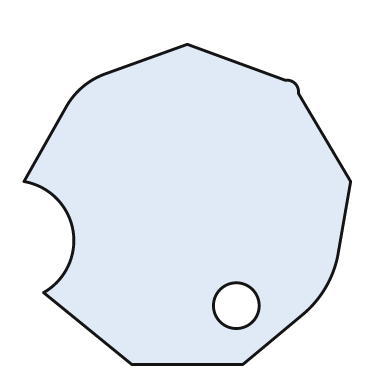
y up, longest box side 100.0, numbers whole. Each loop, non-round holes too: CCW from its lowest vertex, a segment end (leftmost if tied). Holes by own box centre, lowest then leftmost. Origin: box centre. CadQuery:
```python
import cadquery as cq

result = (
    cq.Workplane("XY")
    .moveTo(-17.0, -49.0)
    .lineTo(17.0, -49.0)
    .lineTo(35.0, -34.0)
    .threePointArc((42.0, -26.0), (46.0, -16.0))
    .lineTo(50.0, 7.0)
    .lineTo(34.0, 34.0)
    .threePointArc((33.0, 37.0), (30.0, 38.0))
    .lineTo(0.0, 49.0)
    .lineTo(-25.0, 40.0)
    .threePointArc((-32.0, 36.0), (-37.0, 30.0))
    .lineTo(-50.0, 7.0)
    .threePointArc((-35.0, -8.0), (-44.0, -27.0))
    .close()
    .moveTo(15.0, -31.0)
    .circle(7.0)
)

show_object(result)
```